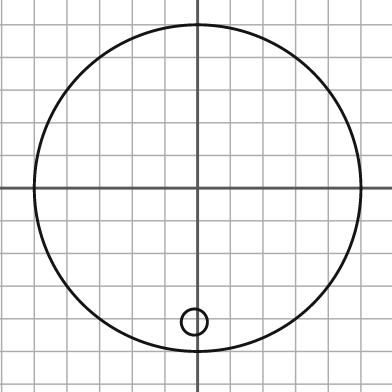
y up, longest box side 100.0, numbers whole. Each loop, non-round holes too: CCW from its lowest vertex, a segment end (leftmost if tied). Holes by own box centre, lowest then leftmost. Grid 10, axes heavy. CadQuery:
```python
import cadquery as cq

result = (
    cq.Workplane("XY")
    .moveTo(0.0, 0.0)
    .circle(50.0)
    .moveTo(-1.0, -41.0)
    .circle(4.0)
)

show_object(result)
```